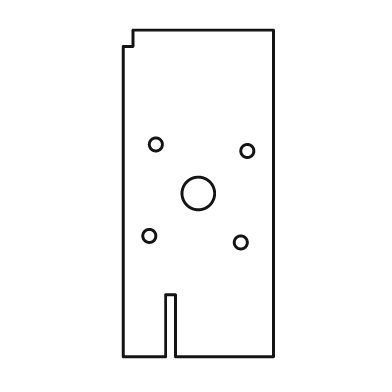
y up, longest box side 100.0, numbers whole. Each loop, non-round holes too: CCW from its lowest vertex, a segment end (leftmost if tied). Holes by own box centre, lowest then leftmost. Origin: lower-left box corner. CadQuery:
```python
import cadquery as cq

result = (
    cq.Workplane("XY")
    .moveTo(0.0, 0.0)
    .lineTo(13.0, 0.0)
    .lineTo(13.0, 19.0)
    .lineTo(16.0, 19.0)
    .lineTo(16.0, 0.0)
    .lineTo(46.0, 0.0)
    .lineTo(46.0, 100.0)
    .lineTo(3.0, 100.0)
    .lineTo(3.0, 95.0)
    .lineTo(0.0, 95.0)
    .close()
    .moveTo(36.0, 35.0)
    .circle(2.0)
    .moveTo(8.0, 37.0)
    .circle(2.0)
    .moveTo(23.0, 50.0)
    .circle(5.0)
    .moveTo(38.0, 63.0)
    .circle(2.0)
    .moveTo(10.0, 65.0)
    .circle(2.0)
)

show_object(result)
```